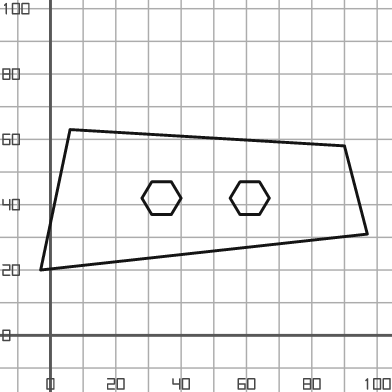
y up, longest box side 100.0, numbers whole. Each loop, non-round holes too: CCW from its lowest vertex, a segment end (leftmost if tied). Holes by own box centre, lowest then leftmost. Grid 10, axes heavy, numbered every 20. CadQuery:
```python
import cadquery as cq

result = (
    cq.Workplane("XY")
    .moveTo(-3.0, 20.0)
    .lineTo(97.0, 31.0)
    .lineTo(90.0, 58.0)
    .lineTo(6.0, 63.0)
    .close()
    .moveTo(31.0, 37.0)
    .lineTo(37.0, 37.0)
    .lineTo(40.0, 42.0)
    .lineTo(37.0, 47.0)
    .lineTo(31.0, 47.0)
    .lineTo(28.0, 42.0)
    .close()
    .moveTo(58.0, 37.0)
    .lineTo(64.0, 37.0)
    .lineTo(67.0, 42.0)
    .lineTo(64.0, 47.0)
    .lineTo(58.0, 47.0)
    .lineTo(55.0, 42.0)
    .close()
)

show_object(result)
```